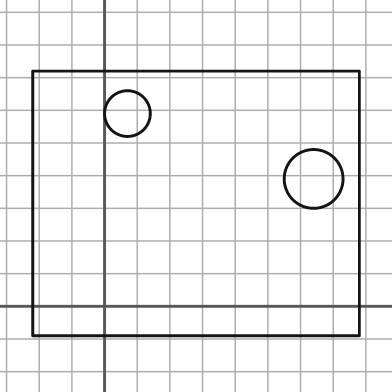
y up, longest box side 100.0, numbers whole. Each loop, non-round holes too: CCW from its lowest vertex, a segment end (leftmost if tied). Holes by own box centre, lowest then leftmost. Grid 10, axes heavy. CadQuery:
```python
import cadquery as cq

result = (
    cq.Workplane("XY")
    .moveTo(-22.0, -9.0)
    .lineTo(78.0, -9.0)
    .lineTo(78.0, 72.0)
    .lineTo(-22.0, 72.0)
    .close()
    .moveTo(64.0, 39.0)
    .circle(9.0)
    .moveTo(7.0, 59.0)
    .circle(7.0)
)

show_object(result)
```